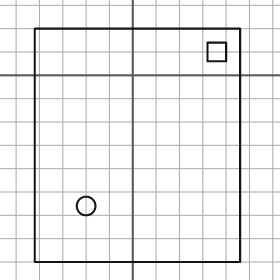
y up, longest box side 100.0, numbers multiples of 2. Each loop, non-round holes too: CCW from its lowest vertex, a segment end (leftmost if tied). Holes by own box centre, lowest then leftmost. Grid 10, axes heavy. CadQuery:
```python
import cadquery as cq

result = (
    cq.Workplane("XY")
    .moveTo(-42.0, -80.0)
    .lineTo(46.0, -80.0)
    .lineTo(46.0, 20.0)
    .lineTo(-42.0, 20.0)
    .close()
    .moveTo(-20.0, -56.0)
    .circle(4.0)
    .moveTo(32.0, 6.0)
    .lineTo(40.0, 6.0)
    .lineTo(40.0, 14.0)
    .lineTo(32.0, 14.0)
    .close()
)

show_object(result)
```